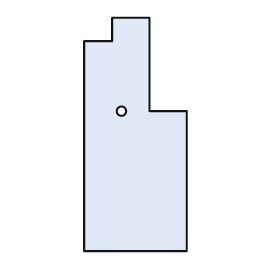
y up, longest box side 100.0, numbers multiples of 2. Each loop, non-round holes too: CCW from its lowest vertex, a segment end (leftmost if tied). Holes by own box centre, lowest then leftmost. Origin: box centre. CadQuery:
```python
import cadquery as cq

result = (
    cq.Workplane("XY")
    .moveTo(-22.0, -50.0)
    .lineTo(22.0, -50.0)
    .lineTo(22.0, 10.0)
    .lineTo(6.0, 10.0)
    .lineTo(6.0, 50.0)
    .lineTo(-10.0, 50.0)
    .lineTo(-10.0, 40.0)
    .lineTo(-22.0, 40.0)
    .close()
    .moveTo(-6.0, 10.0)
    .circle(2.0)
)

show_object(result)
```